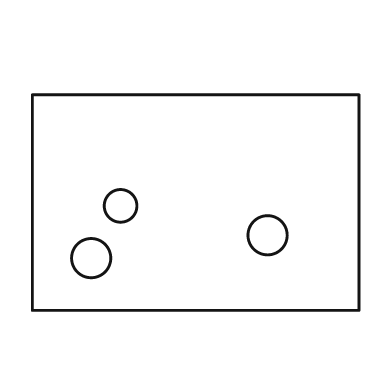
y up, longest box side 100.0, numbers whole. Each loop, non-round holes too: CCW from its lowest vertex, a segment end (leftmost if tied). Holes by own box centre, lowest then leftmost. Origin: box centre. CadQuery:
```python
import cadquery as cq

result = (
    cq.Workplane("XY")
    .moveTo(-50.0, -33.0)
    .lineTo(50.0, -33.0)
    .lineTo(50.0, 33.0)
    .lineTo(-50.0, 33.0)
    .close()
    .moveTo(-32.0, -17.0)
    .circle(6.0)
    .moveTo(22.0, -10.0)
    .circle(6.0)
    .moveTo(-23.0, -1.0)
    .circle(5.0)
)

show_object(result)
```